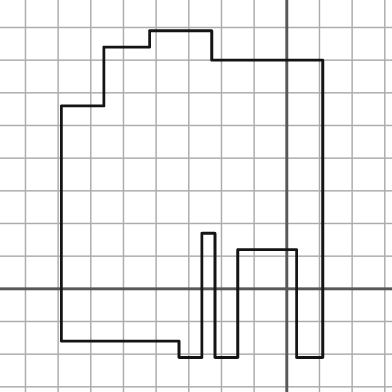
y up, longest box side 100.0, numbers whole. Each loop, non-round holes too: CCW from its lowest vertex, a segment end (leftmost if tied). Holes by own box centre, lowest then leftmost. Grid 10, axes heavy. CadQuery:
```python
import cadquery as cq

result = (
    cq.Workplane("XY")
    .moveTo(-33.0, -21.0)
    .lineTo(-26.0, -21.0)
    .lineTo(-26.0, 17.0)
    .lineTo(-22.0, 17.0)
    .lineTo(-22.0, -21.0)
    .lineTo(-15.0, -21.0)
    .lineTo(-15.0, 12.0)
    .lineTo(3.0, 12.0)
    .lineTo(3.0, -21.0)
    .lineTo(11.0, -21.0)
    .lineTo(11.0, 70.0)
    .lineTo(-23.0, 70.0)
    .lineTo(-23.0, 79.0)
    .lineTo(-42.0, 79.0)
    .lineTo(-42.0, 74.0)
    .lineTo(-56.0, 74.0)
    .lineTo(-56.0, 56.0)
    .lineTo(-69.0, 56.0)
    .lineTo(-69.0, -16.0)
    .lineTo(-33.0, -16.0)
    .close()
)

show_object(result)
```